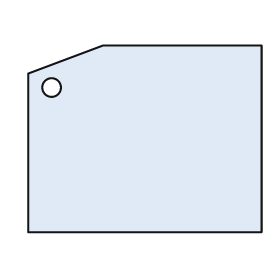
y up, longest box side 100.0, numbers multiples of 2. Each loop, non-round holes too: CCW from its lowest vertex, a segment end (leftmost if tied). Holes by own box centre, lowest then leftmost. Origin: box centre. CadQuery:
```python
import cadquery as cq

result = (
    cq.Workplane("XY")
    .moveTo(-50.0, -40.0)
    .lineTo(50.0, -40.0)
    .lineTo(50.0, 40.0)
    .lineTo(-18.0, 40.0)
    .lineTo(-50.0, 28.0)
    .close()
    .moveTo(-40.0, 22.0)
    .circle(4.0)
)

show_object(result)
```